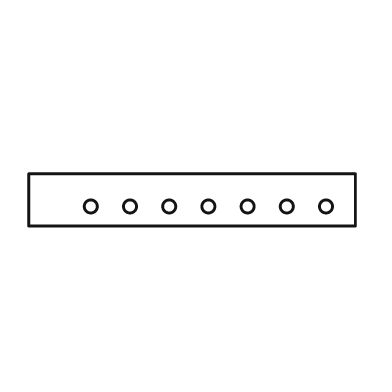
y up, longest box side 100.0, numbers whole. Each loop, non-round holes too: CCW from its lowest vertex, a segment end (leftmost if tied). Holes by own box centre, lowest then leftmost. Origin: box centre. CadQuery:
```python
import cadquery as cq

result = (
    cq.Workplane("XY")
    .moveTo(-50.0, -8.0)
    .lineTo(50.0, -8.0)
    .lineTo(50.0, 8.0)
    .lineTo(-50.0, 8.0)
    .close()
    .moveTo(-31.0, -2.0)
    .circle(2.0)
    .moveTo(-19.0, -2.0)
    .circle(2.0)
    .moveTo(-7.0, -2.0)
    .circle(2.0)
    .moveTo(5.0, -2.0)
    .circle(2.0)
    .moveTo(17.0, -2.0)
    .circle(2.0)
    .moveTo(29.0, -2.0)
    .circle(2.0)
    .moveTo(41.0, -2.0)
    .circle(2.0)
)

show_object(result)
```